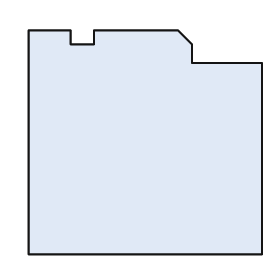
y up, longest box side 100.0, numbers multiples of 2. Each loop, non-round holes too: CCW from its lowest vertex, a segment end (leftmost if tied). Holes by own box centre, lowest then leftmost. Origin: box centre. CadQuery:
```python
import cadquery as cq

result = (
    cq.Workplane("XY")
    .moveTo(-50.0, -48.0)
    .lineTo(50.0, -48.0)
    .lineTo(50.0, 34.0)
    .lineTo(20.0, 34.0)
    .lineTo(20.0, 42.0)
    .lineTo(14.0, 48.0)
    .lineTo(-22.0, 48.0)
    .lineTo(-22.0, 42.0)
    .lineTo(-32.0, 42.0)
    .lineTo(-32.0, 48.0)
    .lineTo(-50.0, 48.0)
    .close()
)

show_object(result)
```